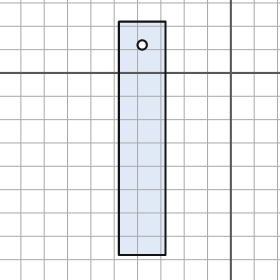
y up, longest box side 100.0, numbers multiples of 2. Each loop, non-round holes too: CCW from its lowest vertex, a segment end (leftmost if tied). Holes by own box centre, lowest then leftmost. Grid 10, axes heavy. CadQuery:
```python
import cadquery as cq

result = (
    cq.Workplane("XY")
    .moveTo(-48.0, -78.0)
    .lineTo(-28.0, -78.0)
    .lineTo(-28.0, 22.0)
    .lineTo(-48.0, 22.0)
    .close()
    .moveTo(-38.0, 12.0)
    .circle(2.0)
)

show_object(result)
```